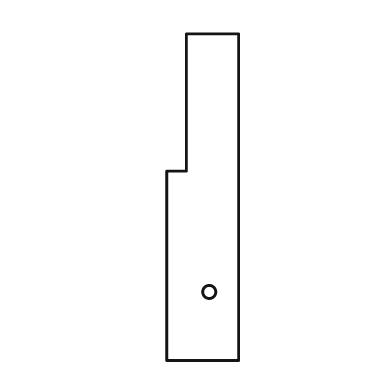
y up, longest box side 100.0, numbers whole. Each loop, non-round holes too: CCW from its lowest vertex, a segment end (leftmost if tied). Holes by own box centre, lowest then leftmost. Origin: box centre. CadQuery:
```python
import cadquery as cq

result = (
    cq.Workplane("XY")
    .moveTo(-11.0, -50.0)
    .lineTo(11.0, -50.0)
    .lineTo(11.0, 50.0)
    .lineTo(-5.0, 50.0)
    .lineTo(-5.0, 8.0)
    .lineTo(-11.0, 8.0)
    .close()
    .moveTo(2.0, -29.0)
    .circle(2.0)
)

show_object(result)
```